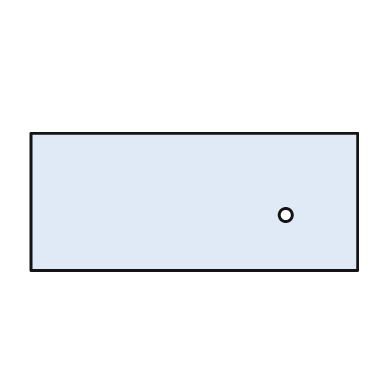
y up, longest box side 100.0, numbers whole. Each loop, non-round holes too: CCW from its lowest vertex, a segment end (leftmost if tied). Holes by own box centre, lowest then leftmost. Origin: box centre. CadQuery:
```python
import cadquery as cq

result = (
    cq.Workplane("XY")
    .moveTo(-50.0, -21.0)
    .lineTo(50.0, -21.0)
    .lineTo(50.0, 21.0)
    .lineTo(-50.0, 21.0)
    .close()
    .moveTo(28.0, -4.0)
    .circle(2.0)
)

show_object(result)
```